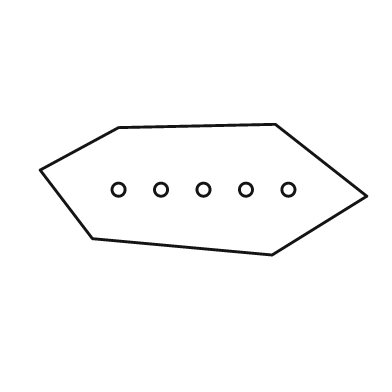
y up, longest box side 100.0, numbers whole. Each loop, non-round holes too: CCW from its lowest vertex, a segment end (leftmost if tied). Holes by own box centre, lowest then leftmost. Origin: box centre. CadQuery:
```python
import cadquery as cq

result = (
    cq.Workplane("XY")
    .moveTo(21.0, -20.0)
    .lineTo(50.0, -2.0)
    .lineTo(22.0, 20.0)
    .lineTo(-26.0, 19.0)
    .lineTo(-50.0, 6.0)
    .lineTo(-34.0, -15.0)
    .close()
    .moveTo(-26.0, 0.0)
    .circle(2.0)
    .moveTo(-13.0, 0.0)
    .circle(2.0)
    .moveTo(0.0, 0.0)
    .circle(2.0)
    .moveTo(13.0, 0.0)
    .circle(2.0)
    .moveTo(26.0, 0.0)
    .circle(2.0)
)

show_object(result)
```